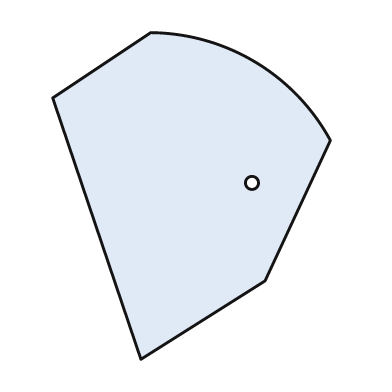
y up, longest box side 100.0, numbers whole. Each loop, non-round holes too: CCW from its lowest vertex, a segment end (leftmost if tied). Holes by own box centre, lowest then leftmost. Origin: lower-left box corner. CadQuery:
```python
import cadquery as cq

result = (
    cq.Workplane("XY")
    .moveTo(27.0, 0.0)
    .lineTo(65.0, 24.0)
    .lineTo(85.0, 67.0)
    .threePointArc((62.0, 91.0), (30.0, 100.0))
    .lineTo(0.0, 80.0)
    .close()
    .moveTo(61.0, 54.0)
    .circle(2.0)
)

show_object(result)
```